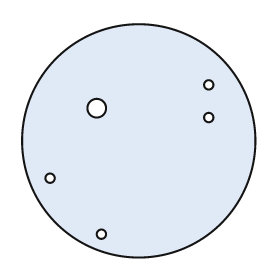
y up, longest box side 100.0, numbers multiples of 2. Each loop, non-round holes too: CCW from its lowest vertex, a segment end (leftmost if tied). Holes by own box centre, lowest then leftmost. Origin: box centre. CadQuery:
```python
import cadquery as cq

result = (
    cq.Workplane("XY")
    .moveTo(0.0, 0.0)
    .circle(50.0)
    .moveTo(-16.0, -40.0)
    .circle(2.0)
    .moveTo(-38.0, -16.0)
    .circle(2.0)
    .moveTo(30.0, 10.0)
    .circle(2.0)
    .moveTo(-18.0, 14.0)
    .circle(4.0)
    .moveTo(30.0, 24.0)
    .circle(2.0)
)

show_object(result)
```